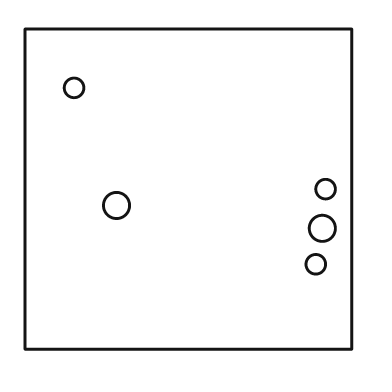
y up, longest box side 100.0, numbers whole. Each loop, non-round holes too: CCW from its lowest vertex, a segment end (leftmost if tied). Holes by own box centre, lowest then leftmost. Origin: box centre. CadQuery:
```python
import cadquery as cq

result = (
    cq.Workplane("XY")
    .moveTo(-50.0, -49.0)
    .lineTo(50.0, -49.0)
    .lineTo(50.0, 49.0)
    .lineTo(-50.0, 49.0)
    .close()
    .moveTo(39.0, -23.0)
    .circle(3.0)
    .moveTo(41.0, -12.0)
    .circle(4.0)
    .moveTo(-22.0, -5.0)
    .circle(4.0)
    .moveTo(42.0, 0.0)
    .circle(3.0)
    .moveTo(-35.0, 31.0)
    .circle(3.0)
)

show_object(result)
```